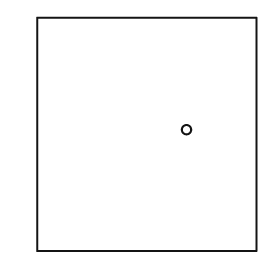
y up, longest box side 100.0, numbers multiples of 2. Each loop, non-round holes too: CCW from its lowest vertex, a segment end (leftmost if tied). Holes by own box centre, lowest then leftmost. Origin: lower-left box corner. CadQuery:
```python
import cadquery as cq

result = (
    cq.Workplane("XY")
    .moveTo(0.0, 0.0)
    .lineTo(94.0, 0.0)
    .lineTo(94.0, 100.0)
    .lineTo(0.0, 100.0)
    .close()
    .moveTo(64.0, 52.0)
    .circle(2.0)
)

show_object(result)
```